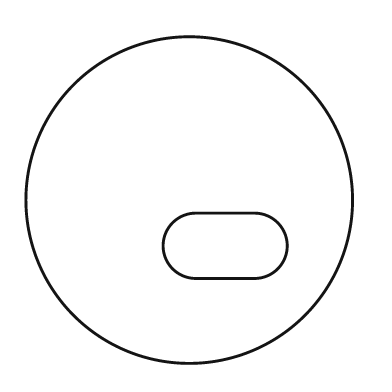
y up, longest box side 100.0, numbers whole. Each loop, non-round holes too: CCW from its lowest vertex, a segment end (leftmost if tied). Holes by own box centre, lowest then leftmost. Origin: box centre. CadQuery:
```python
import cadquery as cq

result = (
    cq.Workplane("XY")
    .moveTo(0.0, 0.0)
    .circle(50.0)
    .moveTo(2.0, -24.0)
    .lineTo(20.0, -24.0)
    .threePointArc((30.0, -14.0), (20.0, -4.0))
    .lineTo(2.0, -4.0)
    .threePointArc((-8.0, -14.0), (2.0, -24.0))
    .close()
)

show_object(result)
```